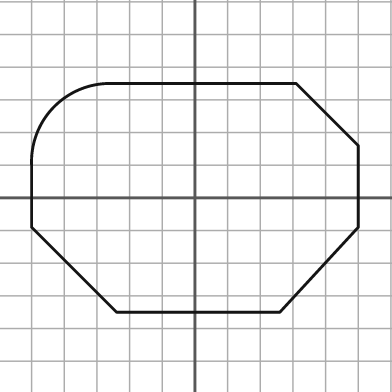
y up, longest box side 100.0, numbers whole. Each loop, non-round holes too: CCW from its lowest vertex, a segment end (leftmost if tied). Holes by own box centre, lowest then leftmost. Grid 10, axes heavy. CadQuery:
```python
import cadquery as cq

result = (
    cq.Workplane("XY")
    .moveTo(-24.0, -35.0)
    .lineTo(26.0, -35.0)
    .lineTo(50.0, -9.0)
    .lineTo(50.0, 16.0)
    .lineTo(31.0, 35.0)
    .lineTo(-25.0, 35.0)
    .threePointArc((-43.0, 28.0), (-50.0, 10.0))
    .lineTo(-50.0, -9.0)
    .close()
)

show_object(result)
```